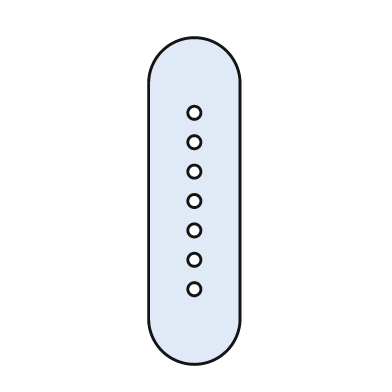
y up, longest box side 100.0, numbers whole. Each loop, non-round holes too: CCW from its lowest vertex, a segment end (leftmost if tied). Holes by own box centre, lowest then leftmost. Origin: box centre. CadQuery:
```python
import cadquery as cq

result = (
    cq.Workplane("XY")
    .moveTo(-14.0, -36.0)
    .threePointArc((0.0, -50.0), (14.0, -36.0))
    .lineTo(14.0, 36.0)
    .threePointArc((0.0, 50.0), (-14.0, 36.0))
    .close()
    .moveTo(0.0, -27.0)
    .circle(2.0)
    .moveTo(0.0, -18.0)
    .circle(2.0)
    .moveTo(0.0, -9.0)
    .circle(2.0)
    .moveTo(0.0, 0.0)
    .circle(2.0)
    .moveTo(0.0, 9.0)
    .circle(2.0)
    .moveTo(0.0, 18.0)
    .circle(2.0)
    .moveTo(0.0, 27.0)
    .circle(2.0)
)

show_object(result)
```